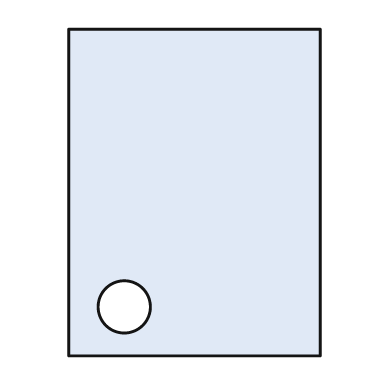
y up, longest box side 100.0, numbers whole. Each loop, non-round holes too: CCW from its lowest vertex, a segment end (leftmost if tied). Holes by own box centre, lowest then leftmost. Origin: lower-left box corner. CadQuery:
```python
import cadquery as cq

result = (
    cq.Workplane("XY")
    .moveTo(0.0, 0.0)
    .lineTo(77.0, 0.0)
    .lineTo(77.0, 100.0)
    .lineTo(0.0, 100.0)
    .close()
    .moveTo(17.0, 15.0)
    .circle(8.0)
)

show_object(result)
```